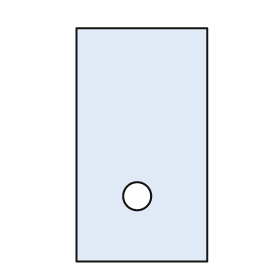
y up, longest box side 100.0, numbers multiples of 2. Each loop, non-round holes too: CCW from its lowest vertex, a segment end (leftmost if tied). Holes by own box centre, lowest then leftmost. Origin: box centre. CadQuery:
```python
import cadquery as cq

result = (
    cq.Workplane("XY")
    .moveTo(-28.0, -50.0)
    .lineTo(28.0, -50.0)
    .lineTo(28.0, 50.0)
    .lineTo(-28.0, 50.0)
    .close()
    .moveTo(-2.0, -22.0)
    .circle(6.0)
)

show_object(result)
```